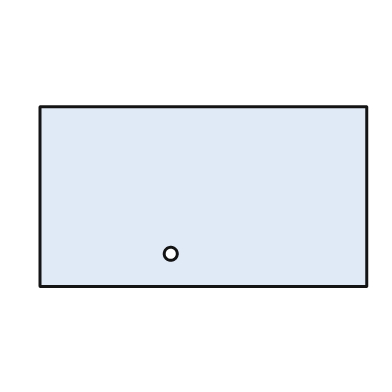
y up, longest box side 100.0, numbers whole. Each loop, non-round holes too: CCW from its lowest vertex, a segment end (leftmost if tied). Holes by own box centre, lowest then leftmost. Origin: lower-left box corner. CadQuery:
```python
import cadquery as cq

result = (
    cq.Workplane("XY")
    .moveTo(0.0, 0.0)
    .lineTo(100.0, 0.0)
    .lineTo(100.0, 55.0)
    .lineTo(0.0, 55.0)
    .close()
    .moveTo(40.0, 10.0)
    .circle(2.0)
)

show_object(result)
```